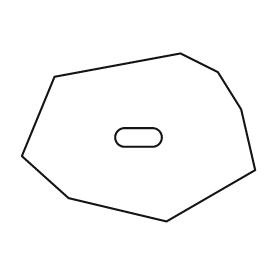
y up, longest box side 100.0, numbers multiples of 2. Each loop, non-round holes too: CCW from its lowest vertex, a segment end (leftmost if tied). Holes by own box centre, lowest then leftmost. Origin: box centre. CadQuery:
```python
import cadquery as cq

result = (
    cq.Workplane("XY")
    .moveTo(12.0, -36.0)
    .lineTo(50.0, -14.0)
    .lineTo(44.0, 12.0)
    .lineTo(34.0, 28.0)
    .lineTo(18.0, 36.0)
    .lineTo(-36.0, 26.0)
    .lineTo(-50.0, -8.0)
    .lineTo(-30.0, -26.0)
    .close()
    .moveTo(-6.0, -4.0)
    .lineTo(6.0, -4.0)
    .threePointArc((10.0, 0.0), (6.0, 4.0))
    .lineTo(-6.0, 4.0)
    .threePointArc((-10.0, 0.0), (-6.0, -4.0))
    .close()
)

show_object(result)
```